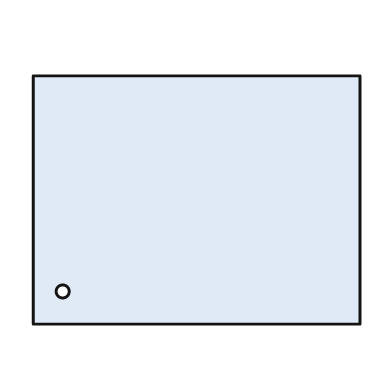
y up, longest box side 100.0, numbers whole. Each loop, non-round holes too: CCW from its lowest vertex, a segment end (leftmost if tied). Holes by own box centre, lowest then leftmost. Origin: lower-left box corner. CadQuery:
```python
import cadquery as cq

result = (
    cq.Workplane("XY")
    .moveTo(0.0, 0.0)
    .lineTo(100.0, 0.0)
    .lineTo(100.0, 76.0)
    .lineTo(0.0, 76.0)
    .close()
    .moveTo(9.0, 10.0)
    .circle(2.0)
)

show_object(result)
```